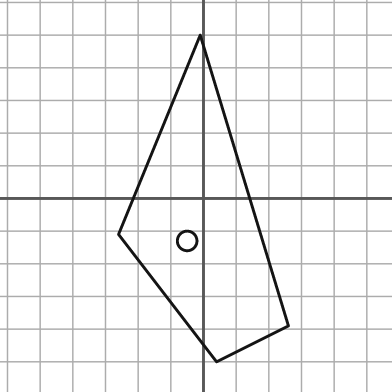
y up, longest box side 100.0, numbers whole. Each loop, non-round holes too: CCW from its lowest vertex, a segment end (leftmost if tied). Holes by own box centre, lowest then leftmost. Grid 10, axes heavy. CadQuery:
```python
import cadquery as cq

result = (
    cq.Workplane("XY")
    .moveTo(4.0, -50.0)
    .lineTo(26.0, -39.0)
    .lineTo(-1.0, 50.0)
    .lineTo(-26.0, -11.0)
    .close()
    .moveTo(-5.0, -13.0)
    .circle(3.0)
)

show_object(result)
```